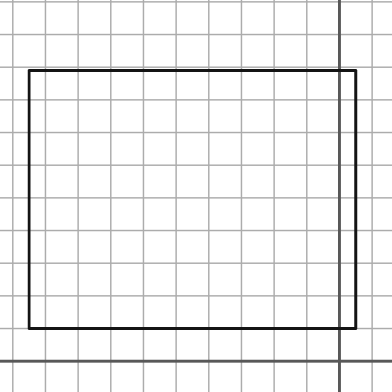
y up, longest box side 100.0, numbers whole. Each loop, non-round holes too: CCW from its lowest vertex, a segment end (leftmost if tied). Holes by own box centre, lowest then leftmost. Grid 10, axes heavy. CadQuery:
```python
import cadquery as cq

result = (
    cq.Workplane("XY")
    .moveTo(-95.0, 10.0)
    .lineTo(5.0, 10.0)
    .lineTo(5.0, 89.0)
    .lineTo(-95.0, 89.0)
    .close()
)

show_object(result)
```